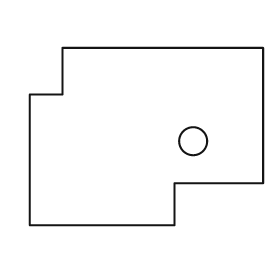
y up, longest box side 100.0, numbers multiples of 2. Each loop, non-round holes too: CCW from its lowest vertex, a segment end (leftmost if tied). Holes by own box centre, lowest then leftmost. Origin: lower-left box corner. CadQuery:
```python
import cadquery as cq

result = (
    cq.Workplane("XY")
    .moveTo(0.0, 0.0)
    .lineTo(62.0, 0.0)
    .lineTo(62.0, 18.0)
    .lineTo(100.0, 18.0)
    .lineTo(100.0, 76.0)
    .lineTo(14.0, 76.0)
    .lineTo(14.0, 56.0)
    .lineTo(0.0, 56.0)
    .close()
    .moveTo(70.0, 36.0)
    .circle(6.0)
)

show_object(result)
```